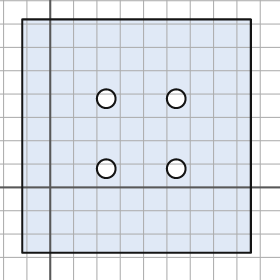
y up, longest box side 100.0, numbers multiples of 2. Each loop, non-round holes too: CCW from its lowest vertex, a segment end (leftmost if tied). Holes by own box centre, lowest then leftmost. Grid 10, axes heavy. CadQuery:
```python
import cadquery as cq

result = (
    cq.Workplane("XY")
    .moveTo(-12.0, -28.0)
    .lineTo(86.0, -28.0)
    .lineTo(86.0, 72.0)
    .lineTo(-12.0, 72.0)
    .close()
    .moveTo(24.0, 8.0)
    .circle(4.0)
    .moveTo(54.0, 8.0)
    .circle(4.0)
    .moveTo(24.0, 38.0)
    .circle(4.0)
    .moveTo(54.0, 38.0)
    .circle(4.0)
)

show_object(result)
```